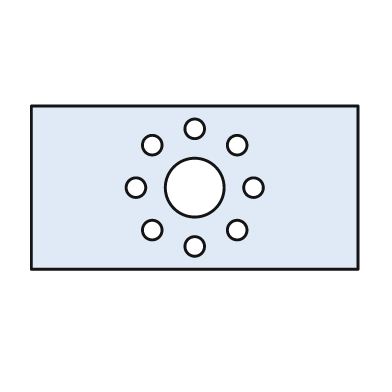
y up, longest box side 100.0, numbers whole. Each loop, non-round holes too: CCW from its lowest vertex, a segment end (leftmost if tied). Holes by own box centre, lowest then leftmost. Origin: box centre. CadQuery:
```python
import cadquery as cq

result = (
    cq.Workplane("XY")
    .moveTo(-50.0, -25.0)
    .lineTo(50.0, -25.0)
    .lineTo(50.0, 25.0)
    .lineTo(-50.0, 25.0)
    .close()
    .moveTo(0.0, -18.0)
    .circle(3.0)
    .moveTo(-13.0, -13.0)
    .circle(3.0)
    .moveTo(13.0, -13.0)
    .circle(3.0)
    .moveTo(-18.0, 0.0)
    .circle(3.0)
    .moveTo(0.0, 0.0)
    .circle(9.0)
    .moveTo(18.0, 0.0)
    .circle(3.0)
    .moveTo(-13.0, 13.0)
    .circle(3.0)
    .moveTo(13.0, 13.0)
    .circle(3.0)
    .moveTo(0.0, 18.0)
    .circle(3.0)
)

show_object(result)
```